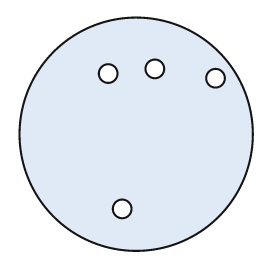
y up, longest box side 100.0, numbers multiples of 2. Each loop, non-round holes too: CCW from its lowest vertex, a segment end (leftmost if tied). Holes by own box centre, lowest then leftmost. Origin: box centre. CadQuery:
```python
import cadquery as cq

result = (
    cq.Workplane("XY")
    .moveTo(0.0, 0.0)
    .circle(50.0)
    .moveTo(-6.0, -32.0)
    .circle(4.0)
    .moveTo(34.0, 24.0)
    .circle(4.0)
    .moveTo(-12.0, 26.0)
    .circle(4.0)
    .moveTo(8.0, 28.0)
    .circle(4.0)
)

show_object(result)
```